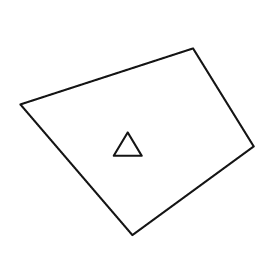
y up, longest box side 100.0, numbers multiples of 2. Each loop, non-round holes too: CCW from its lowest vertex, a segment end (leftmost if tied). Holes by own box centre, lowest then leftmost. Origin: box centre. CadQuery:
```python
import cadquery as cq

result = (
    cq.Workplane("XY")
    .moveTo(-2.0, -40.0)
    .lineTo(50.0, -2.0)
    .lineTo(24.0, 40.0)
    .lineTo(-50.0, 16.0)
    .close()
    .moveTo(-10.0, -6.0)
    .lineTo(2.0, -6.0)
    .lineTo(-4.0, 4.0)
    .close()
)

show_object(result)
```